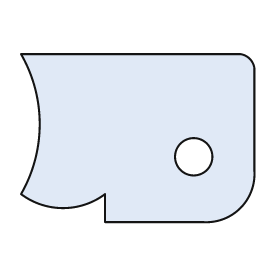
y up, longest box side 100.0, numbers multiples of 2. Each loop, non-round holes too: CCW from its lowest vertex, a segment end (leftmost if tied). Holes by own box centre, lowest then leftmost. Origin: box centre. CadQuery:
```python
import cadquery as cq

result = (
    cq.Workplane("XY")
    .moveTo(-14.0, -36.0)
    .lineTo(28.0, -36.0)
    .threePointArc((44.0, -30.0), (50.0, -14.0))
    .lineTo(50.0, 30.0)
    .threePointArc((48.0, 34.0), (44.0, 36.0))
    .lineTo(-50.0, 36.0)
    .threePointArc((-42.0, 6.0), (-50.0, -24.0))
    .threePointArc((-32.0, -30.0), (-14.0, -24.0))
    .close()
    .moveTo(24.0, -8.0)
    .circle(8.0)
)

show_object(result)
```